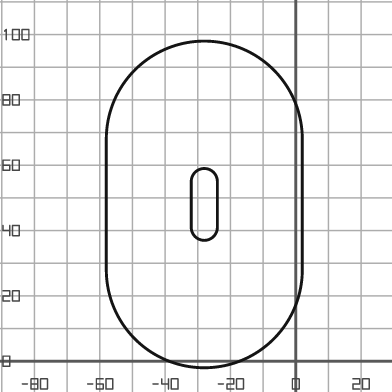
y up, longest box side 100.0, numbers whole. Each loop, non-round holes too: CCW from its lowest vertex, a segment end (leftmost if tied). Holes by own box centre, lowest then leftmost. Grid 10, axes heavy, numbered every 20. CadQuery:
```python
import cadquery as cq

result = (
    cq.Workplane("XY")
    .moveTo(-58.0, 28.0)
    .threePointArc((-28.0, -2.0), (2.0, 28.0))
    .lineTo(2.0, 68.0)
    .threePointArc((-28.0, 98.0), (-58.0, 68.0))
    .close()
    .moveTo(-32.0, 41.0)
    .threePointArc((-28.0, 37.0), (-24.0, 41.0))
    .lineTo(-24.0, 55.0)
    .threePointArc((-28.0, 59.0), (-32.0, 55.0))
    .close()
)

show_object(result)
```